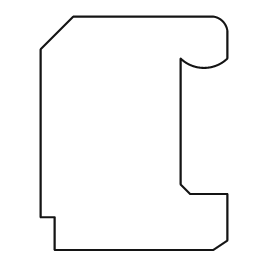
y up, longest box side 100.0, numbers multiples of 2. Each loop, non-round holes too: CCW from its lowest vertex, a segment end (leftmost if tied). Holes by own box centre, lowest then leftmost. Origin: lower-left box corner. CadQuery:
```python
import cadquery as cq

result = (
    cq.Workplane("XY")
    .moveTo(6.0, 0.0)
    .lineTo(74.0, 0.0)
    .lineTo(80.0, 4.0)
    .lineTo(80.0, 24.0)
    .lineTo(64.0, 24.0)
    .lineTo(60.0, 28.0)
    .lineTo(60.0, 82.0)
    .threePointArc((70.0, 78.0), (80.0, 82.0))
    .lineTo(80.0, 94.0)
    .threePointArc((78.0, 98.0), (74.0, 100.0))
    .lineTo(14.0, 100.0)
    .lineTo(0.0, 86.0)
    .lineTo(0.0, 14.0)
    .lineTo(6.0, 14.0)
    .close()
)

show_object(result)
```